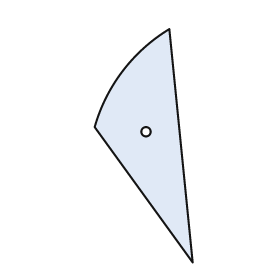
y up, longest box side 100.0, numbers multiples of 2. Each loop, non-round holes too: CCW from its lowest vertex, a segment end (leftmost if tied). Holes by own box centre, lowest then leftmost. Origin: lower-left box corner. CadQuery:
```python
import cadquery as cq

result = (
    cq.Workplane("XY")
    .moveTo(42.0, 0.0)
    .lineTo(32.0, 100.0)
    .threePointArc((12.0, 82.0), (0.0, 58.0))
    .close()
    .moveTo(22.0, 56.0)
    .circle(2.0)
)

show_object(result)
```